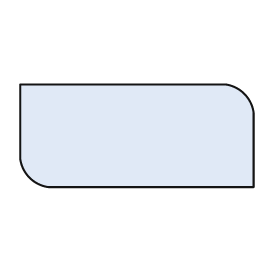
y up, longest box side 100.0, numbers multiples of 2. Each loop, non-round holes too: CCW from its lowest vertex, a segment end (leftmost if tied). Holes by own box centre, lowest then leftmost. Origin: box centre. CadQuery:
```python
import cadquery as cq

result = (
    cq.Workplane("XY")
    .moveTo(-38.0, -22.0)
    .lineTo(50.0, -22.0)
    .lineTo(50.0, 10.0)
    .threePointArc((46.0, 18.0), (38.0, 22.0))
    .lineTo(-50.0, 22.0)
    .lineTo(-50.0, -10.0)
    .threePointArc((-46.0, -18.0), (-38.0, -22.0))
    .close()
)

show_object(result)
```